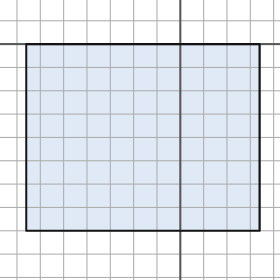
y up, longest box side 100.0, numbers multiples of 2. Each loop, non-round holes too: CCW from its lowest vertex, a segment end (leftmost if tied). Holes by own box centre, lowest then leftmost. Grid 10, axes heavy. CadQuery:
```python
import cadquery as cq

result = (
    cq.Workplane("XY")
    .moveTo(-66.0, -80.0)
    .lineTo(34.0, -80.0)
    .lineTo(34.0, 0.0)
    .lineTo(-66.0, 0.0)
    .close()
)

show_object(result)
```